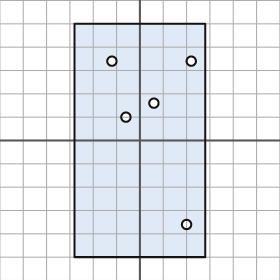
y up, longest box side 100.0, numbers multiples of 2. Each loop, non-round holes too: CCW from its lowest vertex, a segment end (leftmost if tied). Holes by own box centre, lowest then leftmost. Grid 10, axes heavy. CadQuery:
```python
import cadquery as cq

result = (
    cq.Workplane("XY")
    .moveTo(-28.0, -50.0)
    .lineTo(28.0, -50.0)
    .lineTo(28.0, 50.0)
    .lineTo(-28.0, 50.0)
    .close()
    .moveTo(20.0, -36.0)
    .circle(2.0)
    .moveTo(-6.0, 10.0)
    .circle(2.0)
    .moveTo(6.0, 16.0)
    .circle(2.0)
    .moveTo(-12.0, 34.0)
    .circle(2.0)
    .moveTo(22.0, 34.0)
    .circle(2.0)
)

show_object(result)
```